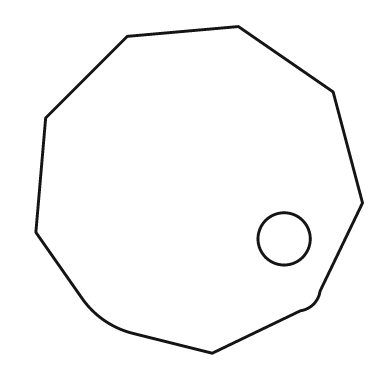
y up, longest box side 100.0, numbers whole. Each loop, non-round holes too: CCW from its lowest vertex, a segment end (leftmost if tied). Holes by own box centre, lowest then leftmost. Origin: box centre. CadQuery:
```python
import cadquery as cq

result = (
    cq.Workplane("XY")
    .moveTo(4.0, -50.0)
    .lineTo(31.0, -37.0)
    .threePointArc((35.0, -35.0), (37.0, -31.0))
    .lineTo(50.0, -4.0)
    .lineTo(41.0, 30.0)
    .lineTo(12.0, 50.0)
    .lineTo(-22.0, 47.0)
    .lineTo(-47.0, 22.0)
    .lineTo(-50.0, -13.0)
    .lineTo(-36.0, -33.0)
    .threePointArc((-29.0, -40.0), (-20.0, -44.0))
    .close()
    .moveTo(26.0, -15.0)
    .circle(8.0)
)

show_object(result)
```